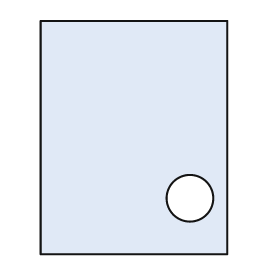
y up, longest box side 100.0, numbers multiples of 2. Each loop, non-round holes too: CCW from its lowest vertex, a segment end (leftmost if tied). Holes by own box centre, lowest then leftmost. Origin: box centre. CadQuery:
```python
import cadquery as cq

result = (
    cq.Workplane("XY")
    .moveTo(-40.0, -50.0)
    .lineTo(40.0, -50.0)
    .lineTo(40.0, 50.0)
    .lineTo(-40.0, 50.0)
    .close()
    .moveTo(24.0, -26.0)
    .circle(10.0)
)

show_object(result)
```